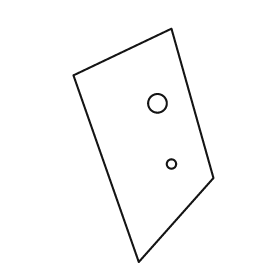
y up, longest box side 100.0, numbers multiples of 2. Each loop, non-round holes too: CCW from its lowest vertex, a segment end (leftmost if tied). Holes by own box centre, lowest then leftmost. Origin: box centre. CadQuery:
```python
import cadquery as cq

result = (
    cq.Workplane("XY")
    .moveTo(-2.0, -50.0)
    .lineTo(30.0, -14.0)
    .lineTo(12.0, 50.0)
    .lineTo(-30.0, 30.0)
    .close()
    .moveTo(12.0, -8.0)
    .circle(2.0)
    .moveTo(6.0, 18.0)
    .circle(4.0)
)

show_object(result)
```